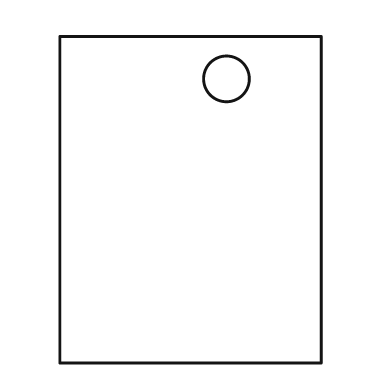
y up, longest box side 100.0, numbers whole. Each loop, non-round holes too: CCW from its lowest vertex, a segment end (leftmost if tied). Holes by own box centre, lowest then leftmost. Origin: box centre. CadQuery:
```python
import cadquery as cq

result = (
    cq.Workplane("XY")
    .moveTo(-40.0, -50.0)
    .lineTo(40.0, -50.0)
    .lineTo(40.0, 50.0)
    .lineTo(-40.0, 50.0)
    .close()
    .moveTo(11.0, 37.0)
    .circle(7.0)
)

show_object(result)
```